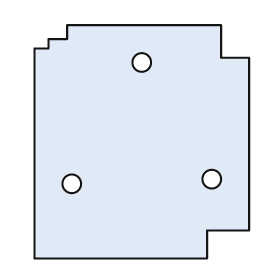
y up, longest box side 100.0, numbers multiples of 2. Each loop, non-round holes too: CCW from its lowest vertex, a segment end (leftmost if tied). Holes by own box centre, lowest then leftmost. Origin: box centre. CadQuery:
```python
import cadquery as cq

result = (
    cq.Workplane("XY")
    .moveTo(-46.0, -50.0)
    .lineTo(28.0, -50.0)
    .lineTo(28.0, -38.0)
    .lineTo(46.0, -38.0)
    .lineTo(46.0, 36.0)
    .lineTo(34.0, 36.0)
    .lineTo(34.0, 50.0)
    .lineTo(-32.0, 50.0)
    .lineTo(-32.0, 44.0)
    .lineTo(-40.0, 44.0)
    .lineTo(-40.0, 40.0)
    .lineTo(-46.0, 40.0)
    .close()
    .moveTo(-30.0, -18.0)
    .circle(4.0)
    .moveTo(30.0, -16.0)
    .circle(4.0)
    .moveTo(0.0, 34.0)
    .circle(4.0)
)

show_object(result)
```